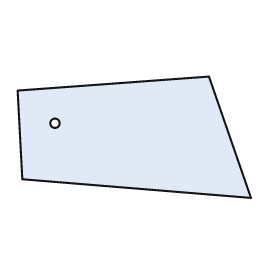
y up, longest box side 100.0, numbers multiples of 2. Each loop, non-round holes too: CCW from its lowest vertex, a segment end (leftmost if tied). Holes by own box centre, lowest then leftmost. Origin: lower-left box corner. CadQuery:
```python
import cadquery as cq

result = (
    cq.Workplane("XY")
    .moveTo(100.0, 0.0)
    .lineTo(82.0, 52.0)
    .lineTo(0.0, 46.0)
    .lineTo(2.0, 8.0)
    .close()
    .moveTo(16.0, 32.0)
    .circle(2.0)
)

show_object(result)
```